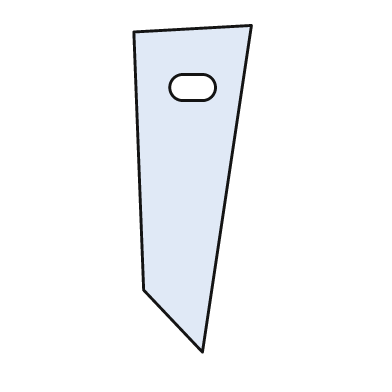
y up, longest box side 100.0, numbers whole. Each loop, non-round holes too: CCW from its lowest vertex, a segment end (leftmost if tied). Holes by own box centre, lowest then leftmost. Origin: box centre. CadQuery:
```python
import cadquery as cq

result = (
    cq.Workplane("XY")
    .moveTo(3.0, -50.0)
    .lineTo(18.0, 50.0)
    .lineTo(-18.0, 48.0)
    .lineTo(-15.0, -31.0)
    .close()
    .moveTo(-3.0, 27.0)
    .lineTo(3.0, 27.0)
    .threePointArc((7.0, 31.0), (3.0, 35.0))
    .lineTo(-3.0, 35.0)
    .threePointArc((-7.0, 31.0), (-3.0, 27.0))
    .close()
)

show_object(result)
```